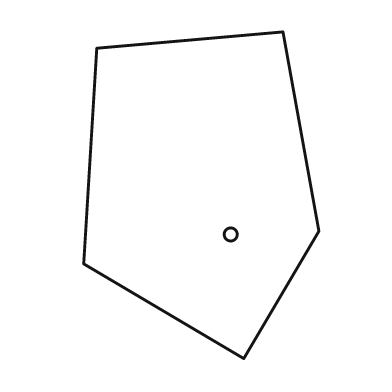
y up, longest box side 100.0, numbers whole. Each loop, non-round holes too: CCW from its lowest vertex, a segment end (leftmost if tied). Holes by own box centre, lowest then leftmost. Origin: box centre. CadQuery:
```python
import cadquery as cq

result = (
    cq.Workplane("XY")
    .moveTo(13.0, -50.0)
    .lineTo(36.0, -11.0)
    .lineTo(25.0, 50.0)
    .lineTo(-32.0, 45.0)
    .lineTo(-36.0, -21.0)
    .close()
    .moveTo(9.0, -12.0)
    .circle(2.0)
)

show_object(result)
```